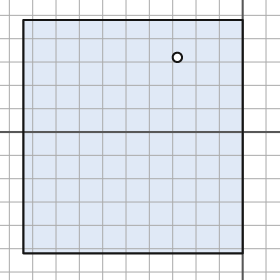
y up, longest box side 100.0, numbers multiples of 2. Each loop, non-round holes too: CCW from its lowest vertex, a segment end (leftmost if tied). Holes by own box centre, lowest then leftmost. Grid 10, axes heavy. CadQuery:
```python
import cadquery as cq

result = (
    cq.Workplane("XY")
    .moveTo(-94.0, -52.0)
    .lineTo(0.0, -52.0)
    .lineTo(0.0, 48.0)
    .lineTo(-94.0, 48.0)
    .close()
    .moveTo(-28.0, 32.0)
    .circle(2.0)
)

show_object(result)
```